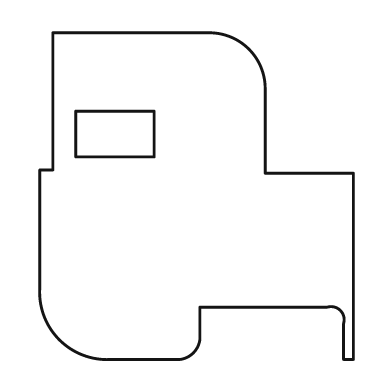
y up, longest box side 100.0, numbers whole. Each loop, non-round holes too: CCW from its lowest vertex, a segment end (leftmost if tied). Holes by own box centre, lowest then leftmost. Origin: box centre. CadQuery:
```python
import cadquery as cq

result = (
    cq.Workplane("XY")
    .moveTo(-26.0, -50.0)
    .lineTo(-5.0, -50.0)
    .threePointArc((-1.0, -48.0), (1.0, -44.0))
    .lineTo(1.0, -34.0)
    .lineTo(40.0, -34.0)
    .threePointArc((44.0, -35.0), (45.0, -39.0))
    .lineTo(45.0, -50.0)
    .lineTo(48.0, -50.0)
    .lineTo(48.0, 7.0)
    .lineTo(21.0, 7.0)
    .lineTo(21.0, 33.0)
    .threePointArc((16.0, 45.0), (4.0, 50.0))
    .lineTo(-44.0, 50.0)
    .lineTo(-44.0, 8.0)
    .lineTo(-48.0, 8.0)
    .lineTo(-48.0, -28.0)
    .threePointArc((-42.0, -44.0), (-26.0, -50.0))
    .close()
    .moveTo(-37.0, 12.0)
    .lineTo(-13.0, 12.0)
    .lineTo(-13.0, 26.0)
    .lineTo(-37.0, 26.0)
    .close()
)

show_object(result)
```